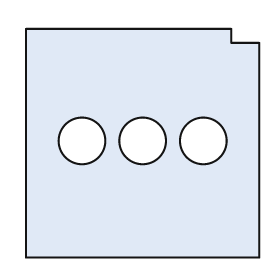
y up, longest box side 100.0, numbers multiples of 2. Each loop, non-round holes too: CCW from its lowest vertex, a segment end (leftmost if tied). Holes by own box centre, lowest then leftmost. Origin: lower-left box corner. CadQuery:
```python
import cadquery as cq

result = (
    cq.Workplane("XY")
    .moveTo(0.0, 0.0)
    .lineTo(100.0, 0.0)
    .lineTo(100.0, 92.0)
    .lineTo(88.0, 92.0)
    .lineTo(88.0, 98.0)
    .lineTo(0.0, 98.0)
    .close()
    .moveTo(24.0, 50.0)
    .circle(10.0)
    .moveTo(50.0, 50.0)
    .circle(10.0)
    .moveTo(76.0, 50.0)
    .circle(10.0)
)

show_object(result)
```